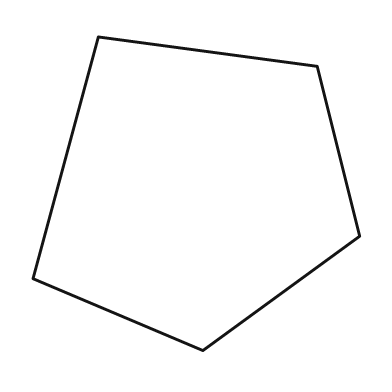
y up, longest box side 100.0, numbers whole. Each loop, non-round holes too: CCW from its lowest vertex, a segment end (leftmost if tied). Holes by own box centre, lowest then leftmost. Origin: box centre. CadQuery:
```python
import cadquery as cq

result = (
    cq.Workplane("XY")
    .moveTo(2.0, -48.0)
    .lineTo(50.0, -13.0)
    .lineTo(37.0, 39.0)
    .lineTo(-30.0, 48.0)
    .lineTo(-50.0, -26.0)
    .close()
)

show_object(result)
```